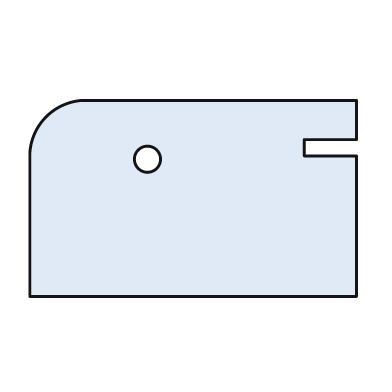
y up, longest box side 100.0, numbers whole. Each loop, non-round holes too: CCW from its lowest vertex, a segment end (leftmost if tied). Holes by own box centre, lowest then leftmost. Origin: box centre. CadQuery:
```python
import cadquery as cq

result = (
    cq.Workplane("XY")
    .moveTo(-50.0, -30.0)
    .lineTo(50.0, -30.0)
    .lineTo(50.0, 13.0)
    .lineTo(34.0, 13.0)
    .lineTo(34.0, 18.0)
    .lineTo(50.0, 18.0)
    .lineTo(50.0, 30.0)
    .lineTo(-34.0, 30.0)
    .threePointArc((-45.0, 25.0), (-50.0, 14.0))
    .close()
    .moveTo(-14.0, 12.0)
    .circle(4.0)
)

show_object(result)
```